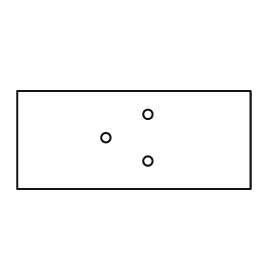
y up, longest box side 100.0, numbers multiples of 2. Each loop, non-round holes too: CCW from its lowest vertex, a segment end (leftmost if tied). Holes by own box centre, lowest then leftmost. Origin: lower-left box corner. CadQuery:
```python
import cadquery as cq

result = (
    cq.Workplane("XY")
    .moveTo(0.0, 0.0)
    .lineTo(100.0, 0.0)
    .lineTo(100.0, 42.0)
    .lineTo(0.0, 42.0)
    .close()
    .moveTo(56.0, 12.0)
    .circle(2.0)
    .moveTo(38.0, 22.0)
    .circle(2.0)
    .moveTo(56.0, 32.0)
    .circle(2.0)
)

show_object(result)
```